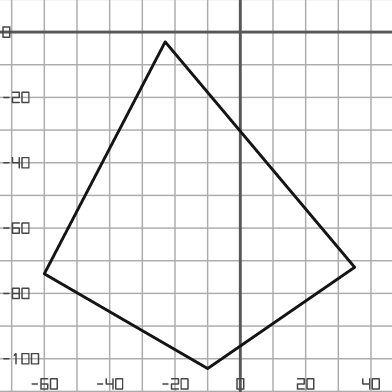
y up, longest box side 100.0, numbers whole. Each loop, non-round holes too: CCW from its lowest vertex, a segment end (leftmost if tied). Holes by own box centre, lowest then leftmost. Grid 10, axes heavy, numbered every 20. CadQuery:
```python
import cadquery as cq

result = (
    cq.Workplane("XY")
    .moveTo(-10.0, -103.0)
    .lineTo(35.0, -72.0)
    .lineTo(-23.0, -3.0)
    .lineTo(-60.0, -74.0)
    .close()
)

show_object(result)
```